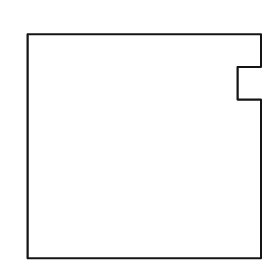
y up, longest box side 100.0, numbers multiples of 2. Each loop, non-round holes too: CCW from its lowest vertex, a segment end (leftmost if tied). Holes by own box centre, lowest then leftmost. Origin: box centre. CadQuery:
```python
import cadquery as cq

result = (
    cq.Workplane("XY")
    .moveTo(-50.0, -48.0)
    .lineTo(50.0, -48.0)
    .lineTo(50.0, 20.0)
    .lineTo(40.0, 20.0)
    .lineTo(40.0, 34.0)
    .lineTo(50.0, 34.0)
    .lineTo(50.0, 48.0)
    .lineTo(-50.0, 48.0)
    .close()
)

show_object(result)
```